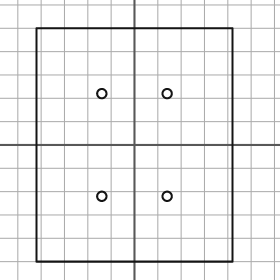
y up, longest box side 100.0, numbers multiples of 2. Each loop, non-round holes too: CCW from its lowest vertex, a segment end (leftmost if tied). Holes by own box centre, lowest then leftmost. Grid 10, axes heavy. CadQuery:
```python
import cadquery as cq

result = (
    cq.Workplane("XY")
    .moveTo(-42.0, -50.0)
    .lineTo(42.0, -50.0)
    .lineTo(42.0, 50.0)
    .lineTo(-42.0, 50.0)
    .close()
    .moveTo(-14.0, -22.0)
    .circle(2.0)
    .moveTo(14.0, -22.0)
    .circle(2.0)
    .moveTo(-14.0, 22.0)
    .circle(2.0)
    .moveTo(14.0, 22.0)
    .circle(2.0)
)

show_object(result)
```